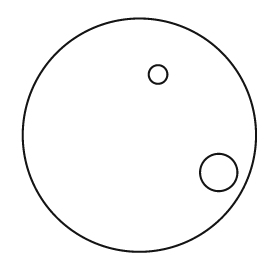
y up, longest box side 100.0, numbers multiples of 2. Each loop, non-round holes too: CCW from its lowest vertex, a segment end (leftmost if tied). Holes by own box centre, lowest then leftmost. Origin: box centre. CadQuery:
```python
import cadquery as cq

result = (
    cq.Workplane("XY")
    .moveTo(0.0, 0.0)
    .circle(50.0)
    .moveTo(34.0, -16.0)
    .circle(8.0)
    .moveTo(8.0, 26.0)
    .circle(4.0)
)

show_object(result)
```